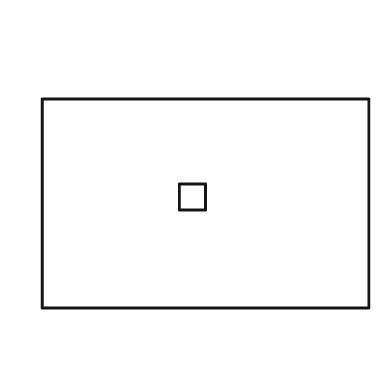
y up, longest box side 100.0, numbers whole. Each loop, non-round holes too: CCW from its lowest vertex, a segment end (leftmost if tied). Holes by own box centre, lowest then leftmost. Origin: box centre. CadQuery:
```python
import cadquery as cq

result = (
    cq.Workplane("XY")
    .moveTo(-50.0, -32.0)
    .lineTo(50.0, -32.0)
    .lineTo(50.0, 32.0)
    .lineTo(-50.0, 32.0)
    .close()
    .moveTo(-8.0, -2.0)
    .lineTo(0.0, -2.0)
    .lineTo(0.0, 6.0)
    .lineTo(-8.0, 6.0)
    .close()
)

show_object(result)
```